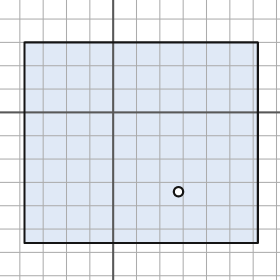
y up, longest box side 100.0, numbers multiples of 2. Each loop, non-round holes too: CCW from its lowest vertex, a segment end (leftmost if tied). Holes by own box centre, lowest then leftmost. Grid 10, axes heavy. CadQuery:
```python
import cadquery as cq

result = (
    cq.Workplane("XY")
    .moveTo(-38.0, -56.0)
    .lineTo(62.0, -56.0)
    .lineTo(62.0, 30.0)
    .lineTo(-38.0, 30.0)
    .close()
    .moveTo(28.0, -34.0)
    .circle(2.0)
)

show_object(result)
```